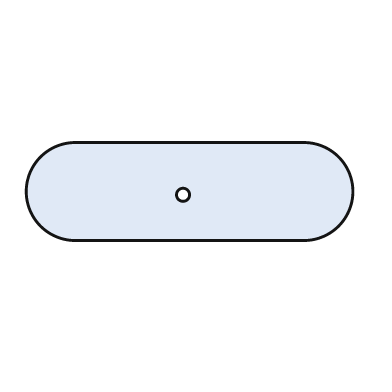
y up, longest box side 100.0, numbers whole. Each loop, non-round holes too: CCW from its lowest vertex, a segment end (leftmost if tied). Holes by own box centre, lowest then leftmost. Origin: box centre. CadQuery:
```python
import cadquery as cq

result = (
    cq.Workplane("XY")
    .moveTo(-35.0, -15.0)
    .lineTo(35.0, -15.0)
    .threePointArc((50.0, 0.0), (35.0, 15.0))
    .lineTo(-35.0, 15.0)
    .threePointArc((-50.0, 0.0), (-35.0, -15.0))
    .close()
    .moveTo(-2.0, -1.0)
    .circle(2.0)
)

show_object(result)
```